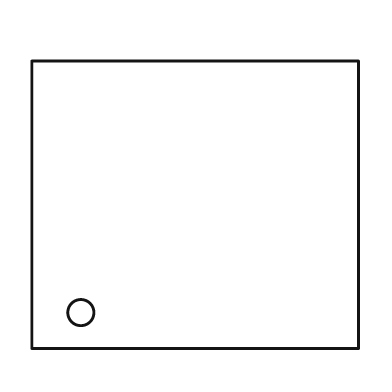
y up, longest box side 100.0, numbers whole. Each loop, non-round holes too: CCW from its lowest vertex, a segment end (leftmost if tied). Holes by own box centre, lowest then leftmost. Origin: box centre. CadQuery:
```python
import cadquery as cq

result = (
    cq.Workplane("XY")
    .moveTo(-50.0, -44.0)
    .lineTo(50.0, -44.0)
    .lineTo(50.0, 44.0)
    .lineTo(-50.0, 44.0)
    .close()
    .moveTo(-35.0, -33.0)
    .circle(4.0)
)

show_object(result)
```